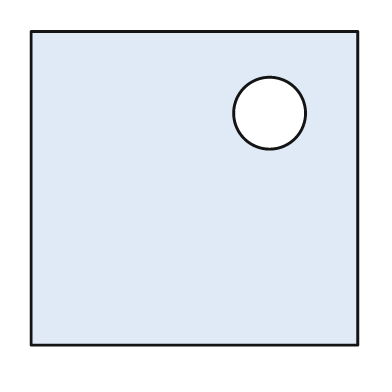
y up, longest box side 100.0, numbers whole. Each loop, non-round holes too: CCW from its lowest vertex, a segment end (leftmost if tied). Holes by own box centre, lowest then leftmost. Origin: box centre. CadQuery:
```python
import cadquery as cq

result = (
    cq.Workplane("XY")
    .moveTo(-50.0, -48.0)
    .lineTo(50.0, -48.0)
    .lineTo(50.0, 48.0)
    .lineTo(-50.0, 48.0)
    .close()
    .moveTo(23.0, 23.0)
    .circle(11.0)
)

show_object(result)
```